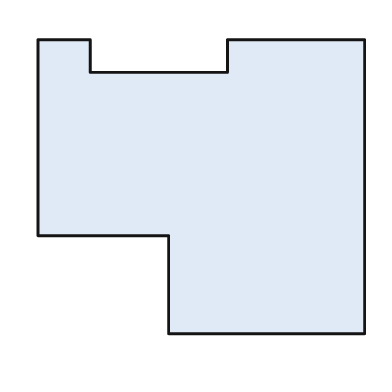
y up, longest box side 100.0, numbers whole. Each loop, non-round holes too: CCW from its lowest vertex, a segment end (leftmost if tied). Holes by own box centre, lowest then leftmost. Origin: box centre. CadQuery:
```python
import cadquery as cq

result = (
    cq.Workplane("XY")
    .moveTo(-10.0, -45.0)
    .lineTo(50.0, -45.0)
    .lineTo(50.0, 45.0)
    .lineTo(8.0, 45.0)
    .lineTo(8.0, 35.0)
    .lineTo(-34.0, 35.0)
    .lineTo(-34.0, 45.0)
    .lineTo(-50.0, 45.0)
    .lineTo(-50.0, -15.0)
    .lineTo(-10.0, -15.0)
    .close()
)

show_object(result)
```